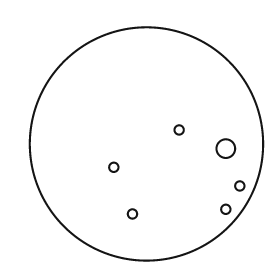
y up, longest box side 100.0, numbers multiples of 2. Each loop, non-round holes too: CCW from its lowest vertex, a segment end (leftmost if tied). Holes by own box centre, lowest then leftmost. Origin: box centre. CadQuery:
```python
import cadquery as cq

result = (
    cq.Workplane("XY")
    .moveTo(0.0, 0.0)
    .circle(50.0)
    .moveTo(-6.0, -30.0)
    .circle(2.0)
    .moveTo(34.0, -28.0)
    .circle(2.0)
    .moveTo(40.0, -18.0)
    .circle(2.0)
    .moveTo(-14.0, -10.0)
    .circle(2.0)
    .moveTo(34.0, -2.0)
    .circle(4.0)
    .moveTo(14.0, 6.0)
    .circle(2.0)
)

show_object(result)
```